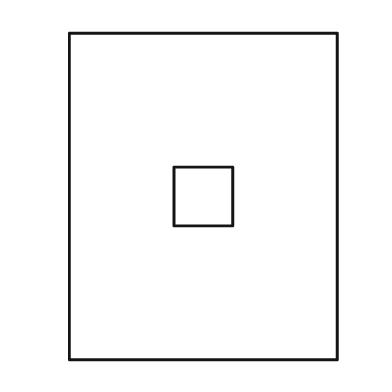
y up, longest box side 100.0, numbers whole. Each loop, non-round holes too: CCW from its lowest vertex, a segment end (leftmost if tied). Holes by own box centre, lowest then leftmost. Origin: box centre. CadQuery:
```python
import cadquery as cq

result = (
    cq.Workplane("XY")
    .moveTo(-41.0, -50.0)
    .lineTo(41.0, -50.0)
    .lineTo(41.0, 50.0)
    .lineTo(-41.0, 50.0)
    .close()
    .moveTo(-9.0, -9.0)
    .lineTo(9.0, -9.0)
    .lineTo(9.0, 9.0)
    .lineTo(-9.0, 9.0)
    .close()
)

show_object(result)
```